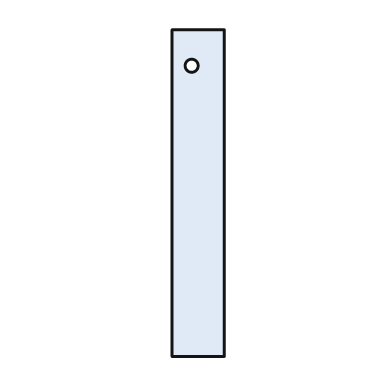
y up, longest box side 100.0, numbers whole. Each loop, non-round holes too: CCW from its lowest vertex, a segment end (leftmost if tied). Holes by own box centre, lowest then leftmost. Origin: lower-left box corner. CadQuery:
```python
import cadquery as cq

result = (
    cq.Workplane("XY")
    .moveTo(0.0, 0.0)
    .lineTo(16.0, 0.0)
    .lineTo(16.0, 100.0)
    .lineTo(0.0, 100.0)
    .close()
    .moveTo(6.0, 89.0)
    .circle(2.0)
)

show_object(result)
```